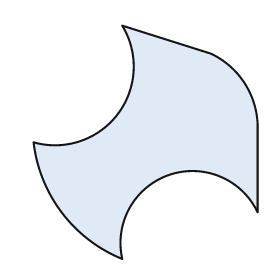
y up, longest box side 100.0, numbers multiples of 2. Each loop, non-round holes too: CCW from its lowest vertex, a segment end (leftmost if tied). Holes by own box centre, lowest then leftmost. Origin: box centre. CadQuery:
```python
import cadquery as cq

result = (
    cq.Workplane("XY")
    .moveTo(-10.0, -50.0)
    .threePointArc((10.0, -14.0), (48.0, -30.0))
    .lineTo(48.0, 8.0)
    .threePointArc((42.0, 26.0), (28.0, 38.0))
    .lineTo(-10.0, 50.0)
    .threePointArc((-12.0, 12.0), (-48.0, 0.0))
    .threePointArc((-36.0, -30.0), (-10.0, -50.0))
    .close()
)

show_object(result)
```